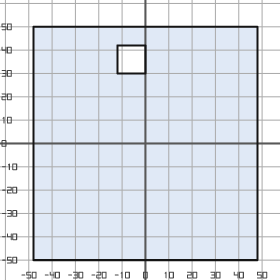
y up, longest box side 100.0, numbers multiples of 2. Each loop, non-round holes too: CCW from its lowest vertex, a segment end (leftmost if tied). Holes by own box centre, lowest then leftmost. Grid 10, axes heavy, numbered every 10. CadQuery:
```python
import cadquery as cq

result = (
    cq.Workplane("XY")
    .moveTo(-48.0, -50.0)
    .lineTo(48.0, -50.0)
    .lineTo(48.0, 50.0)
    .lineTo(-48.0, 50.0)
    .close()
    .moveTo(-12.0, 30.0)
    .lineTo(0.0, 30.0)
    .lineTo(0.0, 42.0)
    .lineTo(-12.0, 42.0)
    .close()
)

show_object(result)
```